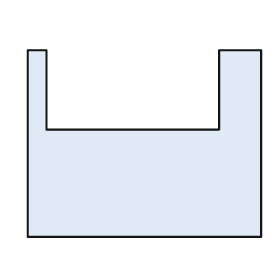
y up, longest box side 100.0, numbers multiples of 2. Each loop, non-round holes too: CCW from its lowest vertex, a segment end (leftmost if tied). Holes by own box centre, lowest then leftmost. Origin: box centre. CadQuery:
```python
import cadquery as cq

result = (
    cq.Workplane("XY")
    .moveTo(-50.0, -40.0)
    .lineTo(50.0, -40.0)
    .lineTo(50.0, 40.0)
    .lineTo(32.0, 40.0)
    .lineTo(32.0, 6.0)
    .lineTo(-42.0, 6.0)
    .lineTo(-42.0, 40.0)
    .lineTo(-50.0, 40.0)
    .close()
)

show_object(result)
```